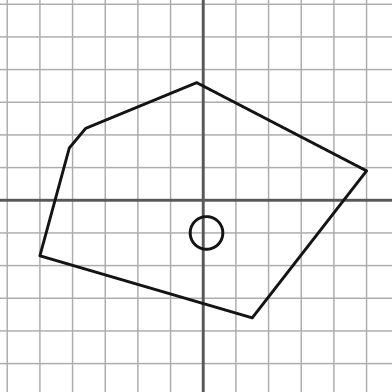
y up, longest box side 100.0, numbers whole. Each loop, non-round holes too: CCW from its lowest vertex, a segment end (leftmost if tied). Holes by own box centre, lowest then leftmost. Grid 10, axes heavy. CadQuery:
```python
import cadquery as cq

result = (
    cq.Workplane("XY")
    .moveTo(15.0, -36.0)
    .lineTo(50.0, 9.0)
    .lineTo(-2.0, 36.0)
    .lineTo(-36.0, 22.0)
    .lineTo(-41.0, 16.0)
    .lineTo(-50.0, -17.0)
    .close()
    .moveTo(1.0, -10.0)
    .circle(5.0)
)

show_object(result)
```